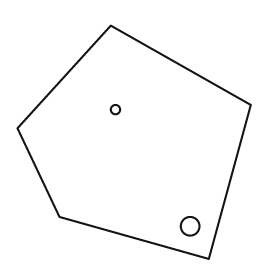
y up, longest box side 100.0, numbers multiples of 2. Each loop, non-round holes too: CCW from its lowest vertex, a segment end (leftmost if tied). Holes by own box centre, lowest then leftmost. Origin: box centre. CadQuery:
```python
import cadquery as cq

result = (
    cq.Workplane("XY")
    .moveTo(32.0, -50.0)
    .lineTo(50.0, 16.0)
    .lineTo(-10.0, 50.0)
    .lineTo(-50.0, 6.0)
    .lineTo(-32.0, -32.0)
    .close()
    .moveTo(24.0, -36.0)
    .circle(4.0)
    .moveTo(-8.0, 14.0)
    .circle(2.0)
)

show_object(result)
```